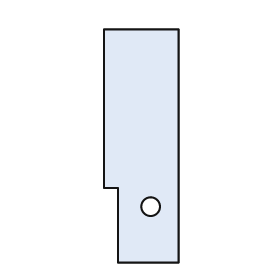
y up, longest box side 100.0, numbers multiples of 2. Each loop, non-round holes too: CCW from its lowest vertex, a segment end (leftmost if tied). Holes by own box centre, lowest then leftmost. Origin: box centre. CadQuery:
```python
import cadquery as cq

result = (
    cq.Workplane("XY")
    .moveTo(-10.0, -50.0)
    .lineTo(16.0, -50.0)
    .lineTo(16.0, 50.0)
    .lineTo(-16.0, 50.0)
    .lineTo(-16.0, -18.0)
    .lineTo(-10.0, -18.0)
    .close()
    .moveTo(4.0, -26.0)
    .circle(4.0)
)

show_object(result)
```